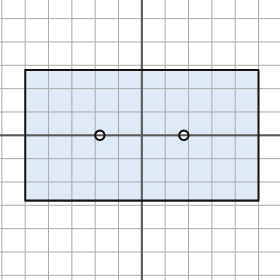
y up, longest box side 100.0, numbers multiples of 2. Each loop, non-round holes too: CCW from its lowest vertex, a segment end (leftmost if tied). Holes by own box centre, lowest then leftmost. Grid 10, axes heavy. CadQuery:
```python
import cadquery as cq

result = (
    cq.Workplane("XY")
    .moveTo(-50.0, -28.0)
    .lineTo(50.0, -28.0)
    .lineTo(50.0, 28.0)
    .lineTo(-50.0, 28.0)
    .close()
    .moveTo(-18.0, 0.0)
    .circle(2.0)
    .moveTo(18.0, 0.0)
    .circle(2.0)
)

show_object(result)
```